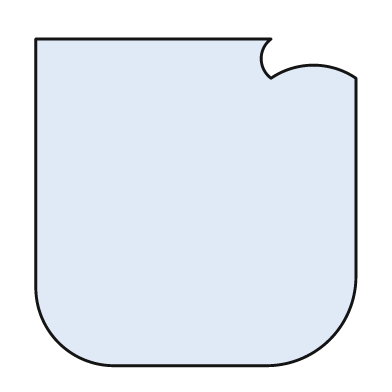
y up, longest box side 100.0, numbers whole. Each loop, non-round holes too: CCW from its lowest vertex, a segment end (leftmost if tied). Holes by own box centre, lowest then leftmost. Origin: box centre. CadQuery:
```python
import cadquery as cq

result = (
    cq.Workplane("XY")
    .moveTo(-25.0, -50.0)
    .lineTo(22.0, -50.0)
    .threePointArc((41.0, -42.0), (49.0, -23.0))
    .lineTo(49.0, 38.0)
    .threePointArc((36.0, 42.0), (23.0, 38.0))
    .threePointArc((20.0, 44.0), (23.0, 50.0))
    .lineTo(-49.0, 50.0)
    .lineTo(-49.0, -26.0)
    .threePointArc((-42.0, -43.0), (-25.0, -50.0))
    .close()
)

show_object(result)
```